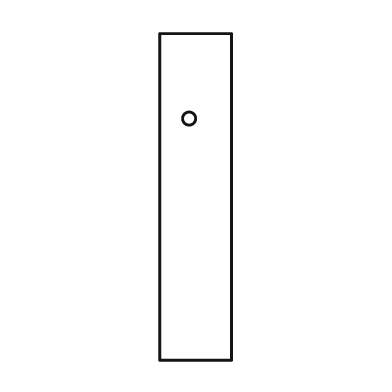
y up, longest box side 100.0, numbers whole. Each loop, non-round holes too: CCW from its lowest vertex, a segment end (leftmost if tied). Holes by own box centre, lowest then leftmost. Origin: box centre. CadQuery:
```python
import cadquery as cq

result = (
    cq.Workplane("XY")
    .moveTo(-11.0, -50.0)
    .lineTo(11.0, -50.0)
    .lineTo(11.0, 50.0)
    .lineTo(-11.0, 50.0)
    .close()
    .moveTo(-2.0, 24.0)
    .circle(2.0)
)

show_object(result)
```